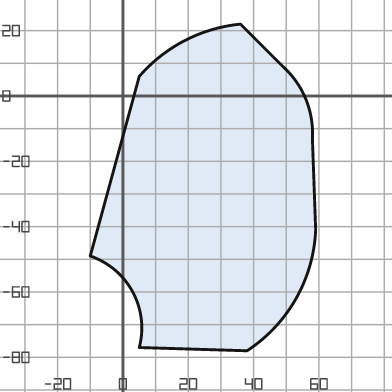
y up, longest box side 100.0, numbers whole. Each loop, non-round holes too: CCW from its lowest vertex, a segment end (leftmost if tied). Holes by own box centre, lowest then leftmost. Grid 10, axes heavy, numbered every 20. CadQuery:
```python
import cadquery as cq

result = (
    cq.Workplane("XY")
    .moveTo(38.0, -78.0)
    .threePointArc((53.0, -62.0), (59.0, -41.0))
    .lineTo(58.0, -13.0)
    .threePointArc((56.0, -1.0), (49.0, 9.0))
    .lineTo(36.0, 22.0)
    .threePointArc((19.0, 17.0), (5.0, 6.0))
    .lineTo(-10.0, -49.0)
    .threePointArc((3.0, -60.0), (5.0, -77.0))
    .close()
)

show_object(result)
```